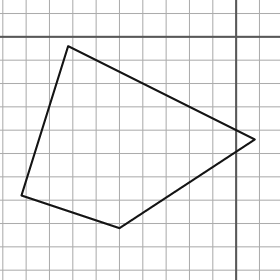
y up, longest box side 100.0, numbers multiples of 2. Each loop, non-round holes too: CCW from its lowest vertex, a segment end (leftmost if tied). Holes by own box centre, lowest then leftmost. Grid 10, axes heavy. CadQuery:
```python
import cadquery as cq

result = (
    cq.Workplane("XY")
    .moveTo(-50.0, -82.0)
    .lineTo(8.0, -44.0)
    .lineTo(-72.0, -4.0)
    .lineTo(-92.0, -68.0)
    .close()
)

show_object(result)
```